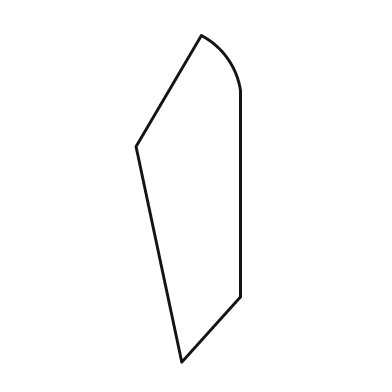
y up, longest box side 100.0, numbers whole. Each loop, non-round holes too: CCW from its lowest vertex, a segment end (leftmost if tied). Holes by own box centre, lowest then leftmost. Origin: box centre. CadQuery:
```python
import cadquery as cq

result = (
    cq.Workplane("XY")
    .moveTo(-2.0, -50.0)
    .lineTo(16.0, -30.0)
    .lineTo(16.0, 33.0)
    .threePointArc((12.0, 43.0), (4.0, 50.0))
    .lineTo(-16.0, 16.0)
    .close()
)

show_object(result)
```